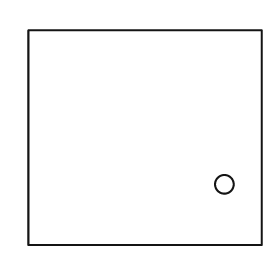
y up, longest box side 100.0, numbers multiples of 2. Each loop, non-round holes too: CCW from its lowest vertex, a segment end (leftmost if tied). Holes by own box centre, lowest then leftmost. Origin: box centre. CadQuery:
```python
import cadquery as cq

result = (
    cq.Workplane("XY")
    .moveTo(-50.0, -46.0)
    .lineTo(50.0, -46.0)
    .lineTo(50.0, 46.0)
    .lineTo(-50.0, 46.0)
    .close()
    .moveTo(34.0, -20.0)
    .circle(4.0)
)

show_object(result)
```